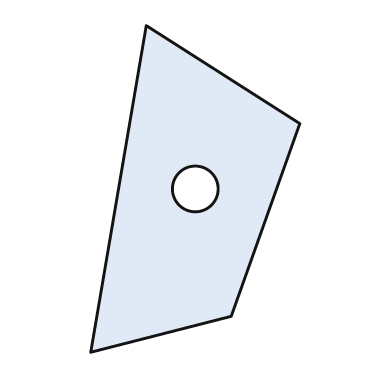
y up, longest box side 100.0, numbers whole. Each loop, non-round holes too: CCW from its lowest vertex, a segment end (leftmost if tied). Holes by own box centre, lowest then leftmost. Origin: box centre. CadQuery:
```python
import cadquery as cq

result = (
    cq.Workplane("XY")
    .moveTo(-32.0, -50.0)
    .lineTo(11.0, -39.0)
    .lineTo(32.0, 20.0)
    .lineTo(-15.0, 50.0)
    .close()
    .moveTo(0.0, 0.0)
    .circle(7.0)
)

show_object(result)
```